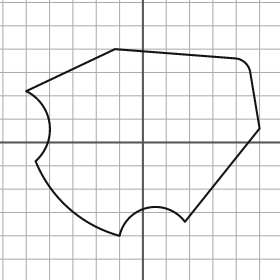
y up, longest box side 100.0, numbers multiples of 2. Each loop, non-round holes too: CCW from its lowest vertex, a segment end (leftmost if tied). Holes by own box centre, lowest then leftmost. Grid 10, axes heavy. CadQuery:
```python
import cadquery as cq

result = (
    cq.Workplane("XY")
    .moveTo(-10.0, -40.0)
    .threePointArc((2.0, -28.0), (18.0, -34.0))
    .lineTo(50.0, 6.0)
    .lineTo(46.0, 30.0)
    .threePointArc((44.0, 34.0), (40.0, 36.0))
    .lineTo(-12.0, 40.0)
    .lineTo(-50.0, 22.0)
    .threePointArc((-40.0, 8.0), (-46.0, -8.0))
    .threePointArc((-32.0, -28.0), (-10.0, -40.0))
    .close()
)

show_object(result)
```